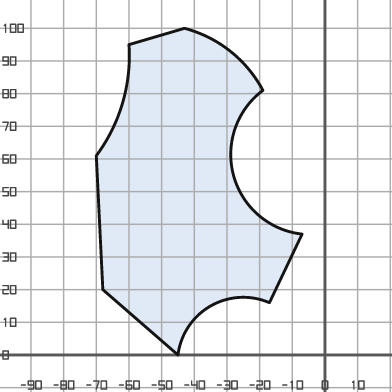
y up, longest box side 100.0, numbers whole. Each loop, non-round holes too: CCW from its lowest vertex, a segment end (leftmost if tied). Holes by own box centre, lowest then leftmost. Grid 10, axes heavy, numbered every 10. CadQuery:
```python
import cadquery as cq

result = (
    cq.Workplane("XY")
    .moveTo(-45.0, 0.0)
    .threePointArc((-35.0, 15.0), (-17.0, 16.0))
    .lineTo(-7.0, 37.0)
    .threePointArc((-28.0, 55.0), (-19.0, 81.0))
    .threePointArc((-29.0, 93.0), (-43.0, 100.0))
    .lineTo(-60.0, 95.0)
    .threePointArc((-62.0, 77.0), (-70.0, 61.0))
    .lineTo(-68.0, 20.0)
    .close()
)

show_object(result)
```